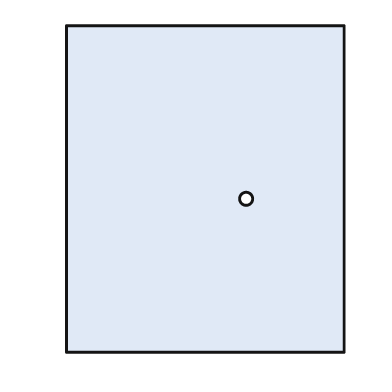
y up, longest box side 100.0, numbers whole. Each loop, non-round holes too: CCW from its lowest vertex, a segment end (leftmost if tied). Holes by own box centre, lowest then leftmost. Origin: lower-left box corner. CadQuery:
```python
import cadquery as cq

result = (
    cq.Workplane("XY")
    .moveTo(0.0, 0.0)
    .lineTo(85.0, 0.0)
    .lineTo(85.0, 100.0)
    .lineTo(0.0, 100.0)
    .close()
    .moveTo(55.0, 47.0)
    .circle(2.0)
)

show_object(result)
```